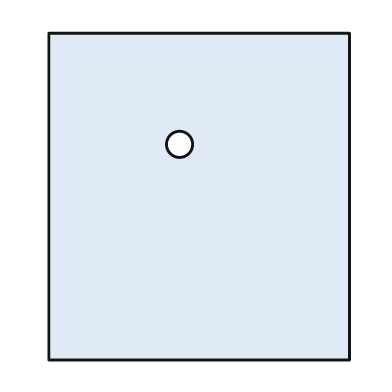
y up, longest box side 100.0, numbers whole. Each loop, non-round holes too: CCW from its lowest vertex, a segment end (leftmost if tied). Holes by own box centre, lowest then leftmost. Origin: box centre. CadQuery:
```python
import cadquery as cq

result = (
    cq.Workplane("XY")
    .moveTo(-46.0, -50.0)
    .lineTo(46.0, -50.0)
    .lineTo(46.0, 50.0)
    .lineTo(-46.0, 50.0)
    .close()
    .moveTo(-6.0, 16.0)
    .circle(4.0)
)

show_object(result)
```